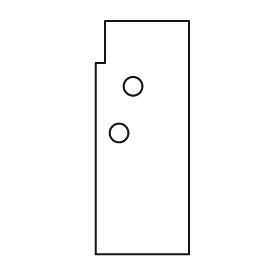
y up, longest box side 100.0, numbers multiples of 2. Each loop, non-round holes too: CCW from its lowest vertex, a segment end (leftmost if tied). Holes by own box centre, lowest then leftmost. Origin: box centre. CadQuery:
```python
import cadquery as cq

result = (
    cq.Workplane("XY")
    .moveTo(-20.0, -50.0)
    .lineTo(20.0, -50.0)
    .lineTo(20.0, 50.0)
    .lineTo(-16.0, 50.0)
    .lineTo(-16.0, 32.0)
    .lineTo(-20.0, 32.0)
    .close()
    .moveTo(-10.0, 2.0)
    .circle(4.0)
    .moveTo(-4.0, 22.0)
    .circle(4.0)
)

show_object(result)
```